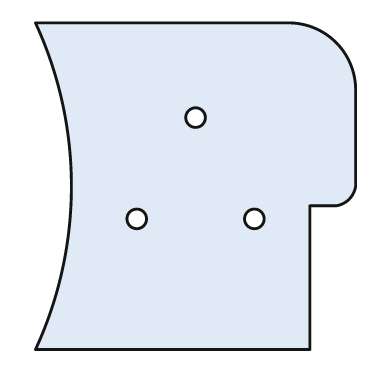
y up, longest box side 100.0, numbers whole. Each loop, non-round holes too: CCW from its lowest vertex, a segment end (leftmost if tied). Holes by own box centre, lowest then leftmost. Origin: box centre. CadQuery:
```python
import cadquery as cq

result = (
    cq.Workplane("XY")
    .moveTo(-49.0, -50.0)
    .lineTo(35.0, -50.0)
    .lineTo(35.0, -6.0)
    .lineTo(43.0, -6.0)
    .threePointArc((47.0, -4.0), (49.0, 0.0))
    .lineTo(49.0, 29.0)
    .threePointArc((43.0, 44.0), (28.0, 50.0))
    .lineTo(-49.0, 50.0)
    .threePointArc((-38.0, 0.0), (-49.0, -50.0))
    .close()
    .moveTo(-18.0, -10.0)
    .circle(3.0)
    .moveTo(18.0, -10.0)
    .circle(3.0)
    .moveTo(0.0, 21.0)
    .circle(3.0)
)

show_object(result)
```